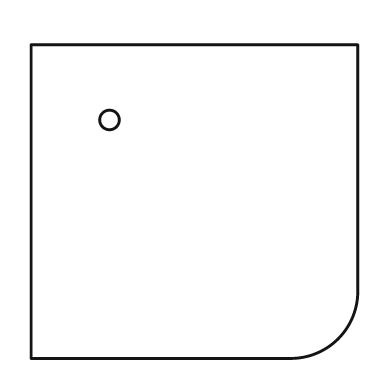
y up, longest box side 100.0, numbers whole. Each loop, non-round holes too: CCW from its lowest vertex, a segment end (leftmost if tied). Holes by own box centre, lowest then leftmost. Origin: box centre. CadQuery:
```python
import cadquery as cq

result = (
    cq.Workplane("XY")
    .moveTo(-50.0, -48.0)
    .lineTo(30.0, -48.0)
    .threePointArc((44.0, -42.0), (50.0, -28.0))
    .lineTo(50.0, 48.0)
    .lineTo(-50.0, 48.0)
    .close()
    .moveTo(-26.0, 25.0)
    .circle(3.0)
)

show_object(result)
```